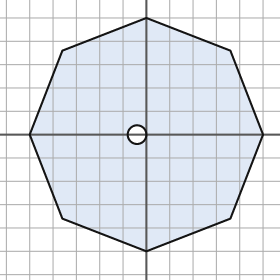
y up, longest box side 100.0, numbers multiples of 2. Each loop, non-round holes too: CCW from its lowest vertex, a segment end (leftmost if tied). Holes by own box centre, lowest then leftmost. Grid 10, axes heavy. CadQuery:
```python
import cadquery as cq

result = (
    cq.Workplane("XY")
    .moveTo(0.0, -50.0)
    .lineTo(36.0, -36.0)
    .lineTo(50.0, 0.0)
    .lineTo(36.0, 36.0)
    .lineTo(0.0, 50.0)
    .lineTo(-36.0, 36.0)
    .lineTo(-50.0, 0.0)
    .lineTo(-36.0, -36.0)
    .close()
    .moveTo(-4.0, 0.0)
    .circle(4.0)
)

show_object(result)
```